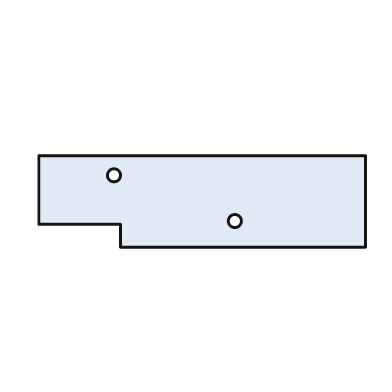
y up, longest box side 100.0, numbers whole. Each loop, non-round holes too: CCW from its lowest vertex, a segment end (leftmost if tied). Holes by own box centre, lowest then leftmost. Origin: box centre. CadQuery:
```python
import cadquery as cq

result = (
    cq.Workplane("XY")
    .moveTo(-25.0, -14.0)
    .lineTo(50.0, -14.0)
    .lineTo(50.0, 14.0)
    .lineTo(-50.0, 14.0)
    .lineTo(-50.0, -7.0)
    .lineTo(-25.0, -7.0)
    .close()
    .moveTo(10.0, -6.0)
    .circle(2.0)
    .moveTo(-27.0, 8.0)
    .circle(2.0)
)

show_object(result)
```